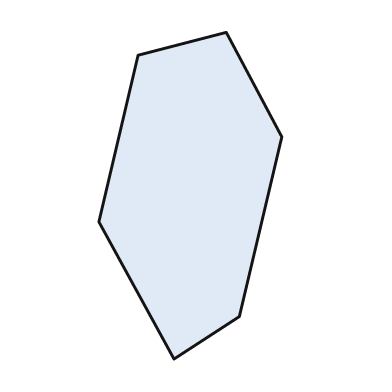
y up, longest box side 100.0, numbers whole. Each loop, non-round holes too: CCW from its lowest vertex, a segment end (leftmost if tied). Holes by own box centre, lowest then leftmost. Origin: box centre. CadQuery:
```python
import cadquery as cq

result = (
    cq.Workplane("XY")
    .moveTo(-5.0, -50.0)
    .lineTo(15.0, -37.0)
    .lineTo(28.0, 18.0)
    .lineTo(11.0, 50.0)
    .lineTo(-16.0, 43.0)
    .lineTo(-28.0, -8.0)
    .close()
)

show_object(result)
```